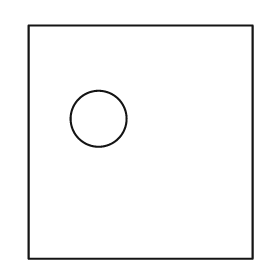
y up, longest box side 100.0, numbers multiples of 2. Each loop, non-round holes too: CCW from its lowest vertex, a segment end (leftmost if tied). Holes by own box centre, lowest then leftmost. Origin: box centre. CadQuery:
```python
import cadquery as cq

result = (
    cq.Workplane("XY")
    .moveTo(-48.0, -50.0)
    .lineTo(48.0, -50.0)
    .lineTo(48.0, 50.0)
    .lineTo(-48.0, 50.0)
    .close()
    .moveTo(-18.0, 10.0)
    .circle(12.0)
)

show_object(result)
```